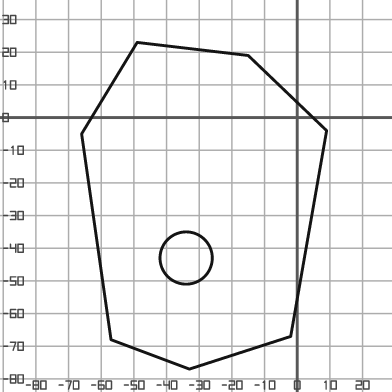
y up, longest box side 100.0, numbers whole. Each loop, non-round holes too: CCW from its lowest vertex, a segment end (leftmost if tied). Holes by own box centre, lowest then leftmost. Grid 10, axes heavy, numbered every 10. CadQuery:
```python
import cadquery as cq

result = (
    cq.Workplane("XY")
    .moveTo(-33.0, -77.0)
    .lineTo(-2.0, -67.0)
    .lineTo(9.0, -4.0)
    .lineTo(-15.0, 19.0)
    .lineTo(-49.0, 23.0)
    .lineTo(-66.0, -5.0)
    .lineTo(-57.0, -68.0)
    .close()
    .moveTo(-34.0, -43.0)
    .circle(8.0)
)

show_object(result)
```